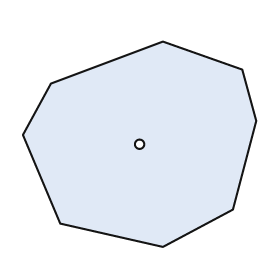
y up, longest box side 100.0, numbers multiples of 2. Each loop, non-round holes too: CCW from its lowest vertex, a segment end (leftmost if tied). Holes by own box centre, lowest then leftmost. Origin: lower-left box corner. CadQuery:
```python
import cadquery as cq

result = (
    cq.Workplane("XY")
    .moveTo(60.0, 0.0)
    .lineTo(90.0, 16.0)
    .lineTo(100.0, 54.0)
    .lineTo(94.0, 76.0)
    .lineTo(60.0, 88.0)
    .lineTo(12.0, 70.0)
    .lineTo(0.0, 48.0)
    .lineTo(16.0, 10.0)
    .close()
    .moveTo(50.0, 44.0)
    .circle(2.0)
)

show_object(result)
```